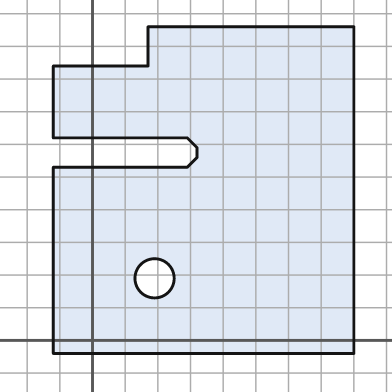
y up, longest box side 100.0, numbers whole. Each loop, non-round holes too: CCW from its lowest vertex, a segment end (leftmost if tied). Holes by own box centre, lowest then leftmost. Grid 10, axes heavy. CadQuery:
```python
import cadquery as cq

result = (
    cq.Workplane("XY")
    .moveTo(-12.0, -4.0)
    .lineTo(80.0, -4.0)
    .lineTo(80.0, 96.0)
    .lineTo(17.0, 96.0)
    .lineTo(17.0, 84.0)
    .lineTo(-12.0, 84.0)
    .lineTo(-12.0, 62.0)
    .lineTo(29.0, 62.0)
    .lineTo(32.0, 59.0)
    .lineTo(32.0, 56.0)
    .lineTo(29.0, 53.0)
    .lineTo(-12.0, 53.0)
    .close()
    .moveTo(19.0, 19.0)
    .circle(6.0)
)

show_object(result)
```